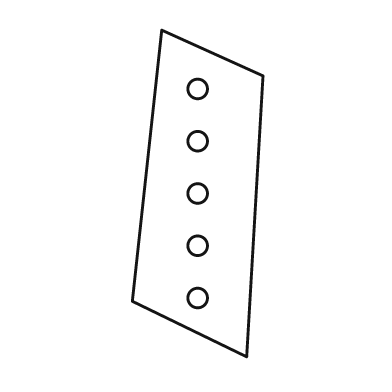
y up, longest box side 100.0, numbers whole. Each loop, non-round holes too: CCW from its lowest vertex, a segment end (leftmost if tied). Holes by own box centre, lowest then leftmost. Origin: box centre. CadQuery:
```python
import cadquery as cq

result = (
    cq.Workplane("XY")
    .moveTo(15.0, -50.0)
    .lineTo(20.0, 36.0)
    .lineTo(-11.0, 50.0)
    .lineTo(-20.0, -33.0)
    .close()
    .moveTo(0.0, -32.0)
    .circle(3.0)
    .moveTo(0.0, -16.0)
    .circle(3.0)
    .moveTo(0.0, 0.0)
    .circle(3.0)
    .moveTo(0.0, 16.0)
    .circle(3.0)
    .moveTo(0.0, 32.0)
    .circle(3.0)
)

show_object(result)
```